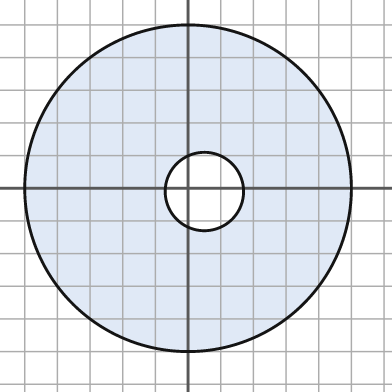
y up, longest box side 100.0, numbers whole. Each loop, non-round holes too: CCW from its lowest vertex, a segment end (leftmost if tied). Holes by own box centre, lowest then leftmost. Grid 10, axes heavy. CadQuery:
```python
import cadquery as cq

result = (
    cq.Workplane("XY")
    .moveTo(0.0, 0.0)
    .circle(50.0)
    .moveTo(5.0, -1.0)
    .circle(12.0)
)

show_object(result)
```